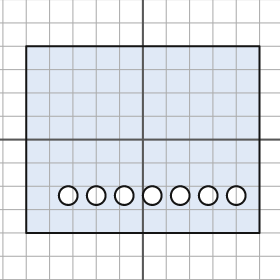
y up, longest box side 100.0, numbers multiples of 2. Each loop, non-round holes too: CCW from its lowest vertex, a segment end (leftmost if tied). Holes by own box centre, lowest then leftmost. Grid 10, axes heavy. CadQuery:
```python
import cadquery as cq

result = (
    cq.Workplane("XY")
    .moveTo(-50.0, -40.0)
    .lineTo(50.0, -40.0)
    .lineTo(50.0, 40.0)
    .lineTo(-50.0, 40.0)
    .close()
    .moveTo(-32.0, -24.0)
    .circle(4.0)
    .moveTo(-20.0, -24.0)
    .circle(4.0)
    .moveTo(-8.0, -24.0)
    .circle(4.0)
    .moveTo(4.0, -24.0)
    .circle(4.0)
    .moveTo(16.0, -24.0)
    .circle(4.0)
    .moveTo(28.0, -24.0)
    .circle(4.0)
    .moveTo(40.0, -24.0)
    .circle(4.0)
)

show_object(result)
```